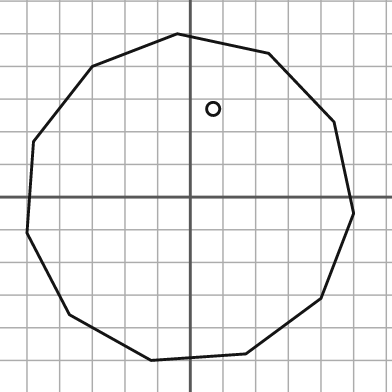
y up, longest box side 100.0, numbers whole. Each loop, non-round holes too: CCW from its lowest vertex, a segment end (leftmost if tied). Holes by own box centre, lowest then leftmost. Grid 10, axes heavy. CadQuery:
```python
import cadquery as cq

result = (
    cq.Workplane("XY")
    .moveTo(-12.0, -50.0)
    .lineTo(17.0, -48.0)
    .lineTo(40.0, -31.0)
    .lineTo(50.0, -5.0)
    .lineTo(44.0, 23.0)
    .lineTo(24.0, 44.0)
    .lineTo(-4.0, 50.0)
    .lineTo(-30.0, 40.0)
    .lineTo(-48.0, 17.0)
    .lineTo(-50.0, -11.0)
    .lineTo(-37.0, -36.0)
    .close()
    .moveTo(7.0, 27.0)
    .circle(2.0)
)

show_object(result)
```